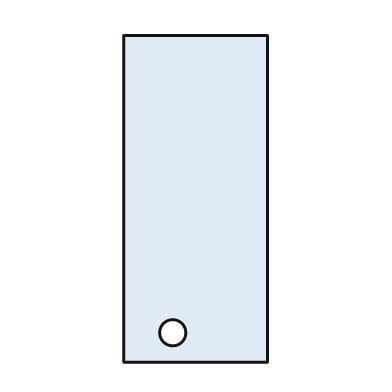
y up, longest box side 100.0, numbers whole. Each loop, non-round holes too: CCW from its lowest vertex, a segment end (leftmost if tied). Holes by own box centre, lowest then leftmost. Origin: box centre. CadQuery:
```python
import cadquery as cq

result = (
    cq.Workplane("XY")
    .moveTo(-22.0, -50.0)
    .lineTo(22.0, -50.0)
    .lineTo(22.0, 50.0)
    .lineTo(-22.0, 50.0)
    .close()
    .moveTo(-7.0, -41.0)
    .circle(4.0)
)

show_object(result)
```